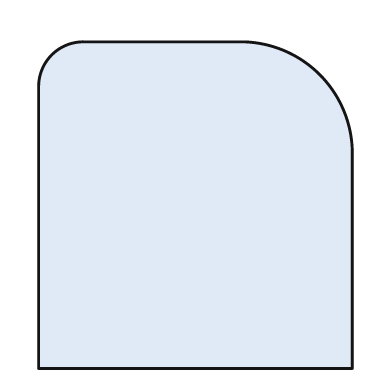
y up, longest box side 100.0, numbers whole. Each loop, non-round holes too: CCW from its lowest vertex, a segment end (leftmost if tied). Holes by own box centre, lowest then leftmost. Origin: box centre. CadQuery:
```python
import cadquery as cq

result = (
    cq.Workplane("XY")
    .moveTo(-48.0, -50.0)
    .lineTo(48.0, -50.0)
    .lineTo(48.0, 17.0)
    .threePointArc((38.0, 40.0), (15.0, 50.0))
    .lineTo(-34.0, 50.0)
    .threePointArc((-44.0, 46.0), (-48.0, 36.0))
    .close()
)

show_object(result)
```